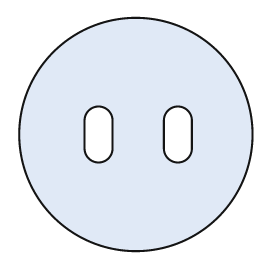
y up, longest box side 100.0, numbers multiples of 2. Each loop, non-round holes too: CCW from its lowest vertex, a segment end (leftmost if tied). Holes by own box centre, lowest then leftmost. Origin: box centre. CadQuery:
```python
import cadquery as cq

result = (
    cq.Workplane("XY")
    .moveTo(0.0, 0.0)
    .circle(50.0)
    .moveTo(-22.0, -6.0)
    .threePointArc((-16.0, -12.0), (-10.0, -6.0))
    .lineTo(-10.0, 6.0)
    .threePointArc((-16.0, 12.0), (-22.0, 6.0))
    .close()
    .moveTo(12.0, -6.0)
    .threePointArc((18.0, -12.0), (24.0, -6.0))
    .lineTo(24.0, 6.0)
    .threePointArc((18.0, 12.0), (12.0, 6.0))
    .close()
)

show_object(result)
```